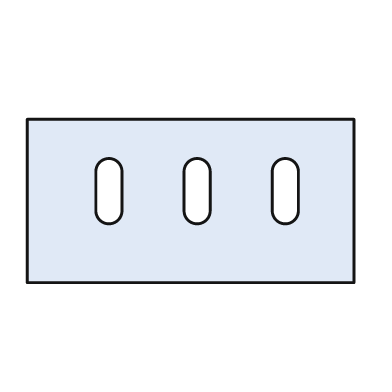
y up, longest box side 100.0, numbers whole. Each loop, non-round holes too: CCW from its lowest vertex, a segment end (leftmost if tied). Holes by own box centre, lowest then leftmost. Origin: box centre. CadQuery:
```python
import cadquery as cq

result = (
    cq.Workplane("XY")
    .moveTo(-50.0, -25.0)
    .lineTo(50.0, -25.0)
    .lineTo(50.0, 25.0)
    .lineTo(-50.0, 25.0)
    .close()
    .moveTo(-29.0, -3.0)
    .threePointArc((-25.0, -7.0), (-21.0, -3.0))
    .lineTo(-21.0, 9.0)
    .threePointArc((-25.0, 13.0), (-29.0, 9.0))
    .close()
    .moveTo(-2.0, -3.0)
    .threePointArc((2.0, -7.0), (6.0, -3.0))
    .lineTo(6.0, 9.0)
    .threePointArc((2.0, 13.0), (-2.0, 9.0))
    .close()
    .moveTo(25.0, -3.0)
    .threePointArc((29.0, -7.0), (33.0, -3.0))
    .lineTo(33.0, 9.0)
    .threePointArc((29.0, 13.0), (25.0, 9.0))
    .close()
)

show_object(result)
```